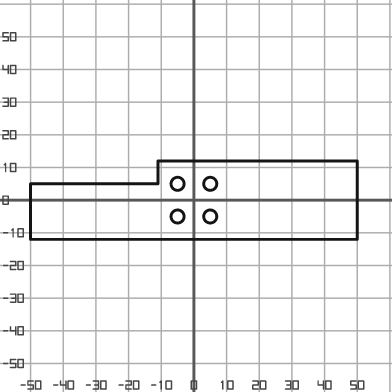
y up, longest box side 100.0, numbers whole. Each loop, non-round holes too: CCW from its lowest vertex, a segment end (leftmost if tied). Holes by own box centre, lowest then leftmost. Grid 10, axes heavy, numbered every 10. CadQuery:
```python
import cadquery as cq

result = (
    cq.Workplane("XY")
    .moveTo(-50.0, -12.0)
    .lineTo(50.0, -12.0)
    .lineTo(50.0, 12.0)
    .lineTo(-11.0, 12.0)
    .lineTo(-11.0, 5.0)
    .lineTo(-50.0, 5.0)
    .close()
    .moveTo(-5.0, -5.0)
    .circle(2.0)
    .moveTo(5.0, -5.0)
    .circle(2.0)
    .moveTo(-5.0, 5.0)
    .circle(2.0)
    .moveTo(5.0, 5.0)
    .circle(2.0)
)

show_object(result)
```